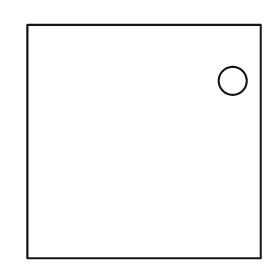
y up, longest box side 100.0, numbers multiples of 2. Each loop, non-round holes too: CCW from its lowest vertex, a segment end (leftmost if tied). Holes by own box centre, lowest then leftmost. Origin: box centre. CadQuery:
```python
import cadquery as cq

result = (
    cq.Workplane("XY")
    .moveTo(-50.0, -50.0)
    .lineTo(50.0, -50.0)
    .lineTo(50.0, 50.0)
    .lineTo(-50.0, 50.0)
    .close()
    .moveTo(38.0, 26.0)
    .circle(6.0)
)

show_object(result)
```